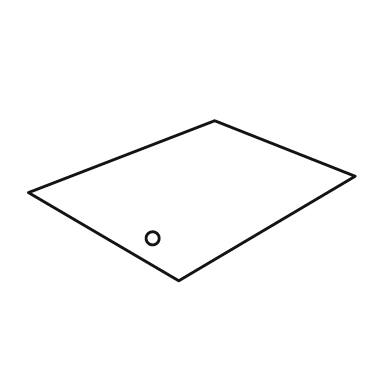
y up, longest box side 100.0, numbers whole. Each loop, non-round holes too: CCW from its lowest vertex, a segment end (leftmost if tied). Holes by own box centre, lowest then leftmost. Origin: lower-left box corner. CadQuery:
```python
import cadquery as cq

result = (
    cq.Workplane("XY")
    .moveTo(46.0, 0.0)
    .lineTo(100.0, 32.0)
    .lineTo(57.0, 49.0)
    .lineTo(0.0, 27.0)
    .close()
    .moveTo(38.0, 13.0)
    .circle(2.0)
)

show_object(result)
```